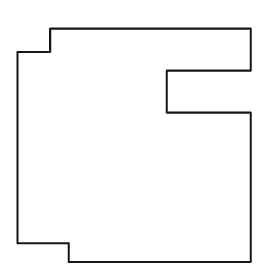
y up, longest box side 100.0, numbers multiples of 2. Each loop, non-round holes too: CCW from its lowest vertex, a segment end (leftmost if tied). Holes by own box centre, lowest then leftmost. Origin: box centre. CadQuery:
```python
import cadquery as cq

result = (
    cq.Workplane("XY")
    .moveTo(-28.0, -50.0)
    .lineTo(50.0, -50.0)
    .lineTo(50.0, 14.0)
    .lineTo(14.0, 14.0)
    .lineTo(14.0, 32.0)
    .lineTo(50.0, 32.0)
    .lineTo(50.0, 50.0)
    .lineTo(-36.0, 50.0)
    .lineTo(-36.0, 40.0)
    .lineTo(-50.0, 40.0)
    .lineTo(-50.0, -42.0)
    .lineTo(-28.0, -42.0)
    .close()
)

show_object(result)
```